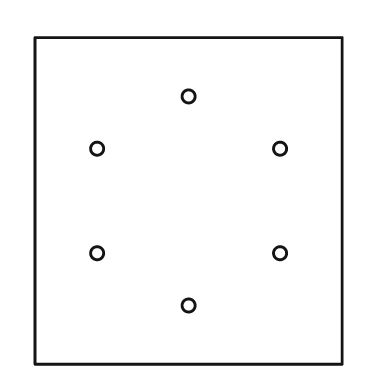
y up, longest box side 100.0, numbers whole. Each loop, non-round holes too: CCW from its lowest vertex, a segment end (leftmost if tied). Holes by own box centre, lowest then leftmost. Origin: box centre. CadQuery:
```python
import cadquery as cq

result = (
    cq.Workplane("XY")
    .moveTo(-47.0, -50.0)
    .lineTo(47.0, -50.0)
    .lineTo(47.0, 50.0)
    .lineTo(-47.0, 50.0)
    .close()
    .moveTo(0.0, -32.0)
    .circle(2.0)
    .moveTo(-28.0, -16.0)
    .circle(2.0)
    .moveTo(28.0, -16.0)
    .circle(2.0)
    .moveTo(-28.0, 16.0)
    .circle(2.0)
    .moveTo(28.0, 16.0)
    .circle(2.0)
    .moveTo(0.0, 32.0)
    .circle(2.0)
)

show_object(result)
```